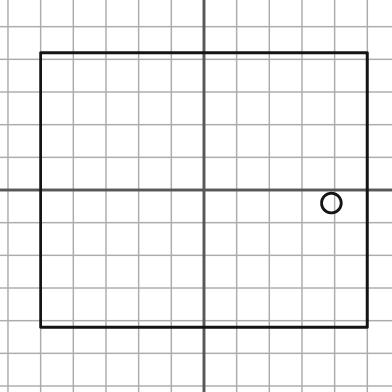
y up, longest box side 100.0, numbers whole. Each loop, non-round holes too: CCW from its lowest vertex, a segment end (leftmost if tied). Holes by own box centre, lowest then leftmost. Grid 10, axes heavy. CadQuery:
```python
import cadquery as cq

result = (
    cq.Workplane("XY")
    .moveTo(-50.0, -42.0)
    .lineTo(50.0, -42.0)
    .lineTo(50.0, 42.0)
    .lineTo(-50.0, 42.0)
    .close()
    .moveTo(39.0, -4.0)
    .circle(3.0)
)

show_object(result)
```